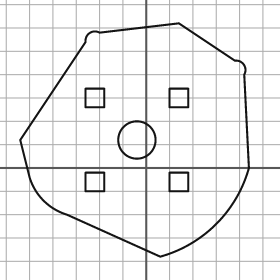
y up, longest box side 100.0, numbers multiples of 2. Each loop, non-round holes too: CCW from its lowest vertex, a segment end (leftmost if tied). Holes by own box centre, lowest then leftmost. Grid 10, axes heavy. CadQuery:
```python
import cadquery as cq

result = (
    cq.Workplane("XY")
    .moveTo(6.0, -38.0)
    .threePointArc((30.0, -24.0), (44.0, 0.0))
    .lineTo(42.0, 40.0)
    .threePointArc((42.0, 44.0), (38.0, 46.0))
    .lineTo(14.0, 62.0)
    .lineTo(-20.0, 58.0)
    .threePointArc((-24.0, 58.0), (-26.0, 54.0))
    .lineTo(-54.0, 12.0)
    .lineTo(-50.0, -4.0)
    .threePointArc((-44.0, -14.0), (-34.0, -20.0))
    .close()
    .moveTo(-26.0, -10.0)
    .lineTo(-18.0, -10.0)
    .lineTo(-18.0, -2.0)
    .lineTo(-26.0, -2.0)
    .close()
    .moveTo(10.0, -10.0)
    .lineTo(18.0, -10.0)
    .lineTo(18.0, -2.0)
    .lineTo(10.0, -2.0)
    .close()
    .moveTo(-4.0, 12.0)
    .circle(8.0)
    .moveTo(-26.0, 26.0)
    .lineTo(-18.0, 26.0)
    .lineTo(-18.0, 34.0)
    .lineTo(-26.0, 34.0)
    .close()
    .moveTo(10.0, 26.0)
    .lineTo(18.0, 26.0)
    .lineTo(18.0, 34.0)
    .lineTo(10.0, 34.0)
    .close()
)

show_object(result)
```